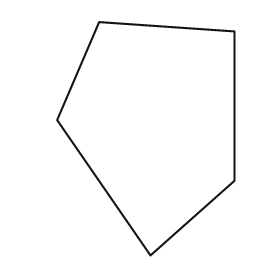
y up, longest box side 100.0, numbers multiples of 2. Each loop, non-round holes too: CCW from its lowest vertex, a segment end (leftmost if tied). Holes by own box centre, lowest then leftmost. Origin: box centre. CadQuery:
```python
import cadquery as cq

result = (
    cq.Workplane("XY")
    .moveTo(2.0, -50.0)
    .lineTo(38.0, -18.0)
    .lineTo(38.0, 46.0)
    .lineTo(-20.0, 50.0)
    .lineTo(-38.0, 8.0)
    .close()
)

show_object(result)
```